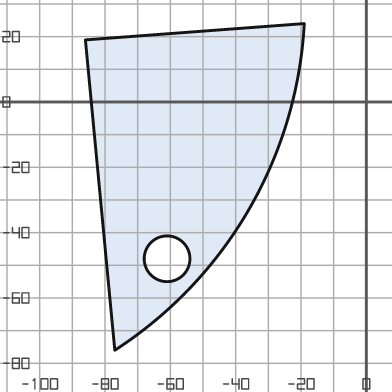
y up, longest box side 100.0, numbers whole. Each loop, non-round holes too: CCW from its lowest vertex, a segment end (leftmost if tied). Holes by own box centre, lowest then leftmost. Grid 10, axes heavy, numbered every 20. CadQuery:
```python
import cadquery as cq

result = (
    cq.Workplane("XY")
    .moveTo(-77.0, -76.0)
    .threePointArc((-36.0, -33.0), (-19.0, 24.0))
    .lineTo(-86.0, 19.0)
    .close()
    .moveTo(-61.0, -48.0)
    .circle(7.0)
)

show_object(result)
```